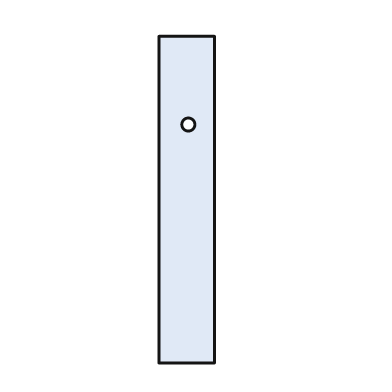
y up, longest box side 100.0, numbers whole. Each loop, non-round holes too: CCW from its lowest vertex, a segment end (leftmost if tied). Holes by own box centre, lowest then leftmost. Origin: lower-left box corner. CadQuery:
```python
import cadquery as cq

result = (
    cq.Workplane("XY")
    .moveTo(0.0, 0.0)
    .lineTo(17.0, 0.0)
    .lineTo(17.0, 100.0)
    .lineTo(0.0, 100.0)
    .close()
    .moveTo(9.0, 73.0)
    .circle(2.0)
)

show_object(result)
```